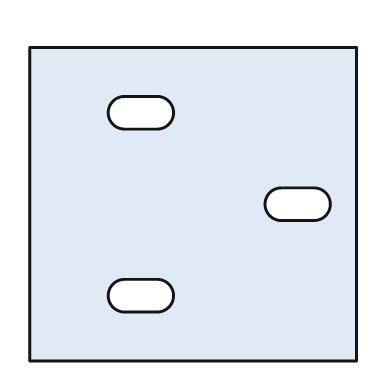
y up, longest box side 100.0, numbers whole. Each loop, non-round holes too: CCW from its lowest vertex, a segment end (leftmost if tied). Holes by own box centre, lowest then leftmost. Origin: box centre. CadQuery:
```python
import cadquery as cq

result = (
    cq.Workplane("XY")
    .moveTo(-50.0, -48.0)
    .lineTo(50.0, -48.0)
    .lineTo(50.0, 48.0)
    .lineTo(-50.0, 48.0)
    .close()
    .moveTo(-21.0, -33.0)
    .lineTo(-11.0, -33.0)
    .threePointArc((-6.0, -28.0), (-11.0, -23.0))
    .lineTo(-21.0, -23.0)
    .threePointArc((-26.0, -28.0), (-21.0, -33.0))
    .close()
    .moveTo(27.0, -5.0)
    .lineTo(37.0, -5.0)
    .threePointArc((42.0, 0.0), (37.0, 5.0))
    .lineTo(27.0, 5.0)
    .threePointArc((22.0, 0.0), (27.0, -5.0))
    .close()
    .moveTo(-21.0, 23.0)
    .lineTo(-11.0, 23.0)
    .threePointArc((-6.0, 28.0), (-11.0, 33.0))
    .lineTo(-21.0, 33.0)
    .threePointArc((-26.0, 28.0), (-21.0, 23.0))
    .close()
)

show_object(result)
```